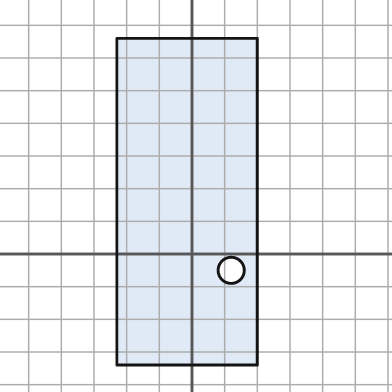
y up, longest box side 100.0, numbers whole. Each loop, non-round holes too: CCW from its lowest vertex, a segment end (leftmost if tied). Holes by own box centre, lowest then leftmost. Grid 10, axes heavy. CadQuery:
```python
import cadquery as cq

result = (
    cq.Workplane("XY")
    .moveTo(-23.0, -34.0)
    .lineTo(20.0, -34.0)
    .lineTo(20.0, 66.0)
    .lineTo(-23.0, 66.0)
    .close()
    .moveTo(12.0, -5.0)
    .circle(4.0)
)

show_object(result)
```